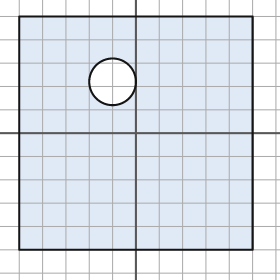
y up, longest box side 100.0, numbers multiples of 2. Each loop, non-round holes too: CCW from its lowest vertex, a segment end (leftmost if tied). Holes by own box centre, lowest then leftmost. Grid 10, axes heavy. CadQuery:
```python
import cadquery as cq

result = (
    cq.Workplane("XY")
    .moveTo(-50.0, -50.0)
    .lineTo(50.0, -50.0)
    .lineTo(50.0, 50.0)
    .lineTo(-50.0, 50.0)
    .close()
    .moveTo(-10.0, 22.0)
    .circle(10.0)
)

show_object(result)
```